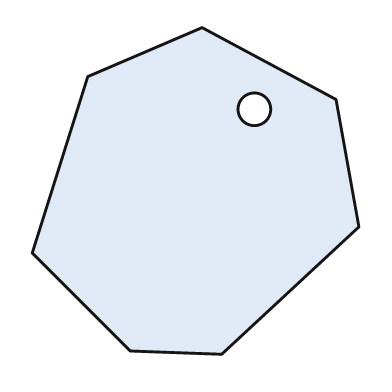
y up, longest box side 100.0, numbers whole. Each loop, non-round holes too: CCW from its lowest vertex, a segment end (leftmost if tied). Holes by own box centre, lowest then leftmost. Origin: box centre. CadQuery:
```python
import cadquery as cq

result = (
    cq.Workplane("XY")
    .moveTo(8.0, -50.0)
    .lineTo(50.0, -11.0)
    .lineTo(43.0, 28.0)
    .lineTo(2.0, 50.0)
    .lineTo(-33.0, 35.0)
    .lineTo(-50.0, -19.0)
    .lineTo(-20.0, -49.0)
    .close()
    .moveTo(18.0, 25.0)
    .circle(5.0)
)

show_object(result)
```